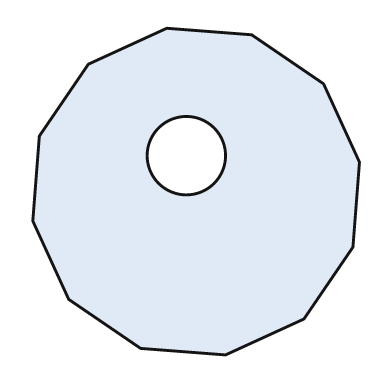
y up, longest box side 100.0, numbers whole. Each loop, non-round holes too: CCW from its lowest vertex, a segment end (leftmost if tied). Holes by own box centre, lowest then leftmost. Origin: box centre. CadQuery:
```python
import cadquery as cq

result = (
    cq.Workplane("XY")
    .moveTo(9.0, -50.0)
    .lineTo(33.0, -39.0)
    .lineTo(48.0, -17.0)
    .lineTo(50.0, 9.0)
    .lineTo(39.0, 33.0)
    .lineTo(17.0, 48.0)
    .lineTo(-9.0, 50.0)
    .lineTo(-33.0, 39.0)
    .lineTo(-48.0, 17.0)
    .lineTo(-50.0, -9.0)
    .lineTo(-39.0, -33.0)
    .lineTo(-17.0, -48.0)
    .close()
    .moveTo(-3.0, 11.0)
    .circle(12.0)
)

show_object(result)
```